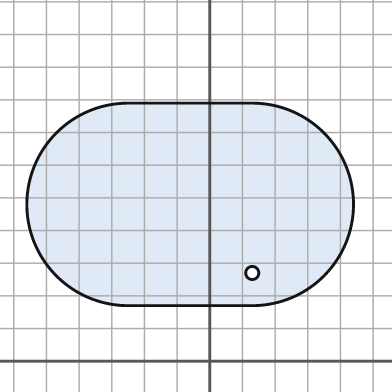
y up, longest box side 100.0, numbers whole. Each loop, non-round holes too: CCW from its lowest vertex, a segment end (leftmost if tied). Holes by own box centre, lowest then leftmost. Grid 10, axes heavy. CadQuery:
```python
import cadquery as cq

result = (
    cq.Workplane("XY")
    .moveTo(-25.0, 17.0)
    .lineTo(13.0, 17.0)
    .threePointArc((44.0, 48.0), (13.0, 79.0))
    .lineTo(-25.0, 79.0)
    .threePointArc((-56.0, 48.0), (-25.0, 17.0))
    .close()
    .moveTo(13.0, 27.0)
    .circle(2.0)
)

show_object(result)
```